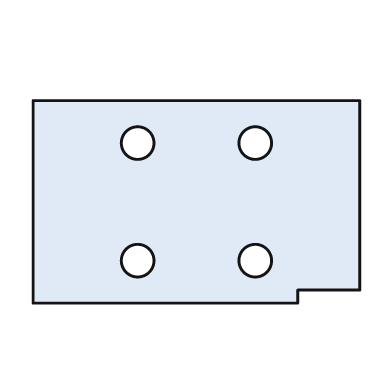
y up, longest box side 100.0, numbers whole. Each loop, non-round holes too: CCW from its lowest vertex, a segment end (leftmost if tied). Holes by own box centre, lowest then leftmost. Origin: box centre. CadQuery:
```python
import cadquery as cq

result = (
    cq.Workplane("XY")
    .moveTo(-50.0, -31.0)
    .lineTo(31.0, -31.0)
    .lineTo(31.0, -27.0)
    .lineTo(50.0, -27.0)
    .lineTo(50.0, 31.0)
    .lineTo(-50.0, 31.0)
    .close()
    .moveTo(-18.0, -18.0)
    .circle(5.0)
    .moveTo(18.0, -18.0)
    .circle(5.0)
    .moveTo(-18.0, 18.0)
    .circle(5.0)
    .moveTo(18.0, 18.0)
    .circle(5.0)
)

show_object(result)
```